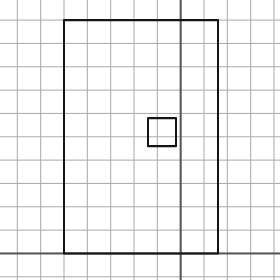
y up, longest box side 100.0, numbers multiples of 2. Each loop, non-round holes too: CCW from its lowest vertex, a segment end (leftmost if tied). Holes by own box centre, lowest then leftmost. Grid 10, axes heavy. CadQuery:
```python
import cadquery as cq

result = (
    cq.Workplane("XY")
    .moveTo(-50.0, 0.0)
    .lineTo(16.0, 0.0)
    .lineTo(16.0, 100.0)
    .lineTo(-50.0, 100.0)
    .close()
    .moveTo(-14.0, 46.0)
    .lineTo(-2.0, 46.0)
    .lineTo(-2.0, 58.0)
    .lineTo(-14.0, 58.0)
    .close()
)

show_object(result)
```